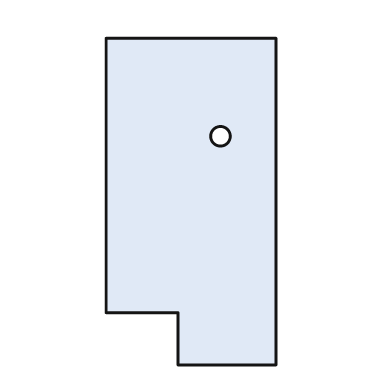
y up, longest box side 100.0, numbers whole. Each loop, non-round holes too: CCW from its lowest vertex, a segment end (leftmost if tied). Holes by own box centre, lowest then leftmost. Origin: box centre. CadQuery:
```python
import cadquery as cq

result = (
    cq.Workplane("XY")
    .moveTo(-4.0, -50.0)
    .lineTo(26.0, -50.0)
    .lineTo(26.0, 50.0)
    .lineTo(-26.0, 50.0)
    .lineTo(-26.0, -34.0)
    .lineTo(-4.0, -34.0)
    .close()
    .moveTo(9.0, 20.0)
    .circle(3.0)
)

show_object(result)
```